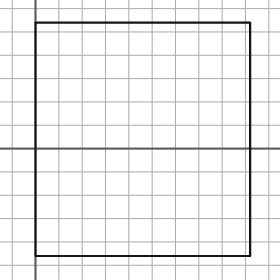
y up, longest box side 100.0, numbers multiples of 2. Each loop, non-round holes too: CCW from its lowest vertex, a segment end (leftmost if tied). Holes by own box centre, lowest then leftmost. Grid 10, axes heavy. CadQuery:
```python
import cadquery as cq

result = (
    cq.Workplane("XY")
    .moveTo(0.0, -46.0)
    .lineTo(92.0, -46.0)
    .lineTo(92.0, 54.0)
    .lineTo(0.0, 54.0)
    .close()
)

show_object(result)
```